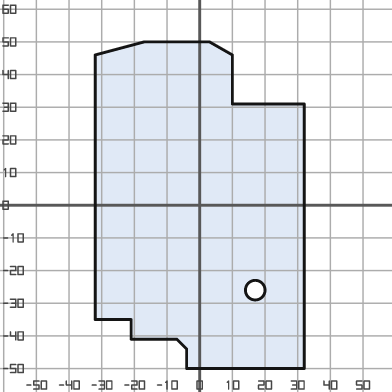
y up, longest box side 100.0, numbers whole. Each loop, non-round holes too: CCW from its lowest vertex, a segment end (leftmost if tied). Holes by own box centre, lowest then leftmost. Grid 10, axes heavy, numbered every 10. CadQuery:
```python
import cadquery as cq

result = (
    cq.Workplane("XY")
    .moveTo(-4.0, -50.0)
    .lineTo(32.0, -50.0)
    .lineTo(32.0, 31.0)
    .lineTo(10.0, 31.0)
    .lineTo(10.0, 46.0)
    .lineTo(3.0, 50.0)
    .lineTo(-17.0, 50.0)
    .lineTo(-32.0, 46.0)
    .lineTo(-32.0, -35.0)
    .lineTo(-21.0, -35.0)
    .lineTo(-21.0, -41.0)
    .lineTo(-7.0, -41.0)
    .lineTo(-4.0, -44.0)
    .close()
    .moveTo(17.0, -26.0)
    .circle(3.0)
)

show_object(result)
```